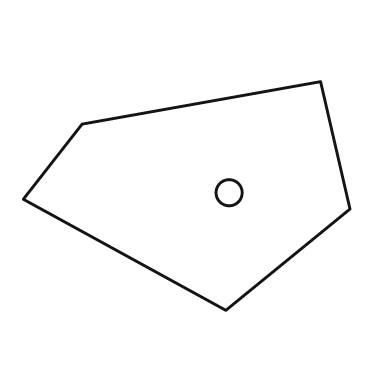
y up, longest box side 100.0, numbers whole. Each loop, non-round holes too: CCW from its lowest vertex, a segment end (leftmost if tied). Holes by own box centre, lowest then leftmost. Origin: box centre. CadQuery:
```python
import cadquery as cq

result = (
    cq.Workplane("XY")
    .moveTo(12.0, -35.0)
    .lineTo(50.0, -4.0)
    .lineTo(41.0, 35.0)
    .lineTo(-32.0, 22.0)
    .lineTo(-50.0, -1.0)
    .close()
    .moveTo(13.0, 1.0)
    .circle(4.0)
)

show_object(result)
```